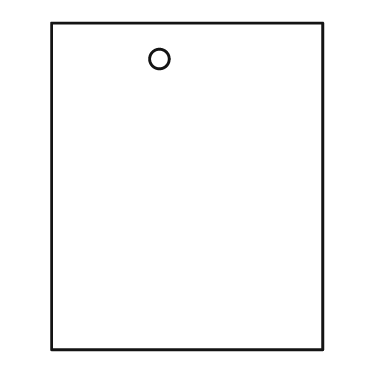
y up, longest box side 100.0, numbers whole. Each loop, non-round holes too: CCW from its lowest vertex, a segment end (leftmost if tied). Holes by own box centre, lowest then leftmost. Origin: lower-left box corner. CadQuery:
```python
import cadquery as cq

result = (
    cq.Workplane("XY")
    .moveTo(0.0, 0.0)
    .lineTo(83.0, 0.0)
    .lineTo(83.0, 100.0)
    .lineTo(0.0, 100.0)
    .close()
    .moveTo(33.0, 89.0)
    .circle(3.0)
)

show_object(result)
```